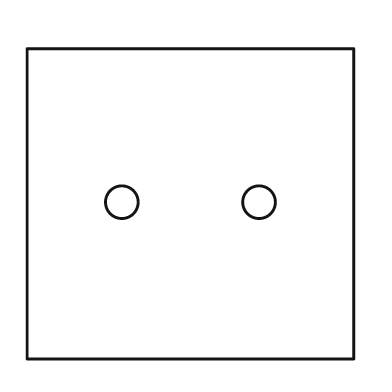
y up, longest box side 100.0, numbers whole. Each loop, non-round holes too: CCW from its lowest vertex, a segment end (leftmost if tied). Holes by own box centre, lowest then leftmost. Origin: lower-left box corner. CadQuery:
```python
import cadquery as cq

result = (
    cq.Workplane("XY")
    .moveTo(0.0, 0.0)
    .lineTo(100.0, 0.0)
    .lineTo(100.0, 95.0)
    .lineTo(0.0, 95.0)
    .close()
    .moveTo(29.0, 48.0)
    .circle(5.0)
    .moveTo(71.0, 48.0)
    .circle(5.0)
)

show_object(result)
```